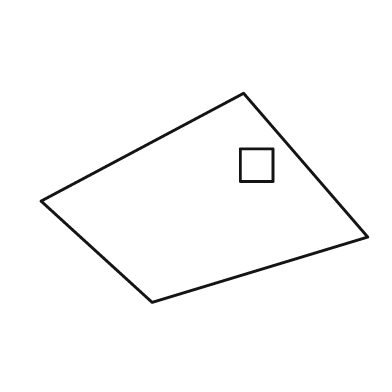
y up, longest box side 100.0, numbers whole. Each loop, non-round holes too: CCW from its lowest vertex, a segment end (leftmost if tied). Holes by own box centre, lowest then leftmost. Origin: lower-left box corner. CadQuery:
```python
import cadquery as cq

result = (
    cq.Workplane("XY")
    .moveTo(34.0, 0.0)
    .lineTo(100.0, 20.0)
    .lineTo(62.0, 64.0)
    .lineTo(0.0, 31.0)
    .close()
    .moveTo(61.0, 37.0)
    .lineTo(71.0, 37.0)
    .lineTo(71.0, 47.0)
    .lineTo(61.0, 47.0)
    .close()
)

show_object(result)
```